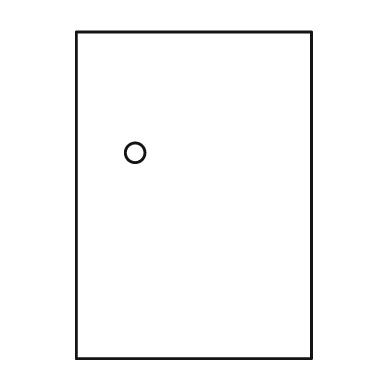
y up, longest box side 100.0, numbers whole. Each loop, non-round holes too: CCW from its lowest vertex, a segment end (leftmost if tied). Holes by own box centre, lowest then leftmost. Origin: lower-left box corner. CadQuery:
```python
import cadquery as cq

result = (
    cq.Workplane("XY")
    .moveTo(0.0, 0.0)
    .lineTo(72.0, 0.0)
    .lineTo(72.0, 100.0)
    .lineTo(0.0, 100.0)
    .close()
    .moveTo(18.0, 63.0)
    .circle(3.0)
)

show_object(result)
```